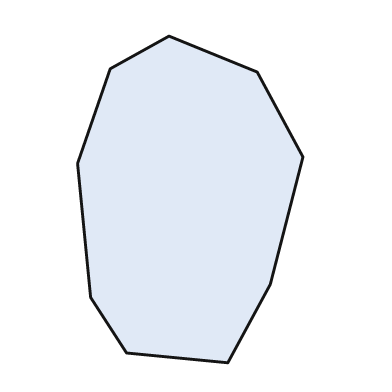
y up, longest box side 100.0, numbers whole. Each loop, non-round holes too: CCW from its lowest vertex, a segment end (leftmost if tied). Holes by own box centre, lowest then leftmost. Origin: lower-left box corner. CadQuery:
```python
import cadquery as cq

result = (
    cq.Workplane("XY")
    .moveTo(46.0, 0.0)
    .lineTo(59.0, 24.0)
    .lineTo(69.0, 63.0)
    .lineTo(55.0, 89.0)
    .lineTo(28.0, 100.0)
    .lineTo(10.0, 90.0)
    .lineTo(0.0, 61.0)
    .lineTo(4.0, 20.0)
    .lineTo(15.0, 3.0)
    .close()
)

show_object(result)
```